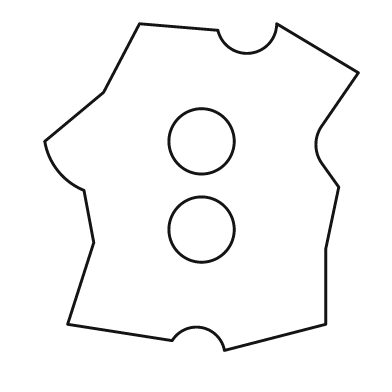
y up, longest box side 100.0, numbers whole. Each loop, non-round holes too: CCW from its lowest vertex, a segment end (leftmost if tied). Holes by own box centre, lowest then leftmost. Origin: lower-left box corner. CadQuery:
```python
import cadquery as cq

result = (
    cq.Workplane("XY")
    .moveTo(55.0, 0.0)
    .lineTo(86.0, 8.0)
    .lineTo(86.0, 31.0)
    .lineTo(90.0, 50.0)
    .lineTo(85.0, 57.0)
    .threePointArc((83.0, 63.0), (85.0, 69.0))
    .lineTo(96.0, 85.0)
    .lineTo(71.0, 100.0)
    .threePointArc((63.0, 91.0), (53.0, 98.0))
    .lineTo(29.0, 100.0)
    .lineTo(18.0, 79.0)
    .lineTo(0.0, 64.0)
    .threePointArc((4.0, 55.0), (12.0, 49.0))
    .lineTo(15.0, 33.0)
    .lineTo(7.0, 8.0)
    .lineTo(39.0, 3.0)
    .threePointArc((48.0, 7.0), (55.0, 0.0))
    .close()
    .moveTo(48.0, 37.0)
    .circle(10.0)
    .moveTo(48.0, 64.0)
    .circle(10.0)
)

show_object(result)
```